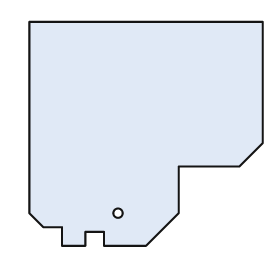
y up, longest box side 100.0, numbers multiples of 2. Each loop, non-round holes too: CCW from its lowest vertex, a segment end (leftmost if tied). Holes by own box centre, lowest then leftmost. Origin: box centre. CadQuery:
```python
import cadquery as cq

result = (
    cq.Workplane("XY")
    .moveTo(-36.0, -48.0)
    .lineTo(-26.0, -48.0)
    .lineTo(-26.0, -42.0)
    .lineTo(-18.0, -42.0)
    .lineTo(-18.0, -48.0)
    .lineTo(0.0, -48.0)
    .lineTo(14.0, -34.0)
    .lineTo(14.0, -14.0)
    .lineTo(40.0, -14.0)
    .lineTo(50.0, -4.0)
    .lineTo(50.0, 48.0)
    .lineTo(-50.0, 48.0)
    .lineTo(-50.0, -34.0)
    .lineTo(-44.0, -40.0)
    .lineTo(-36.0, -40.0)
    .close()
    .moveTo(-12.0, -34.0)
    .circle(2.0)
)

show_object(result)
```